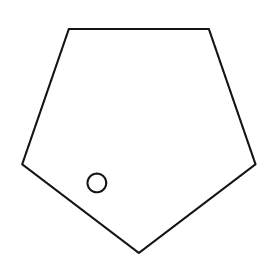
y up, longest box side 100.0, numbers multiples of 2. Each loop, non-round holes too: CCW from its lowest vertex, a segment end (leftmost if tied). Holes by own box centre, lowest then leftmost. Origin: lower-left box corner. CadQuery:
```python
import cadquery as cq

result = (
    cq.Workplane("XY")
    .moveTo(50.0, 0.0)
    .lineTo(100.0, 38.0)
    .lineTo(80.0, 96.0)
    .lineTo(20.0, 96.0)
    .lineTo(0.0, 38.0)
    .close()
    .moveTo(32.0, 30.0)
    .circle(4.0)
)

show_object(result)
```